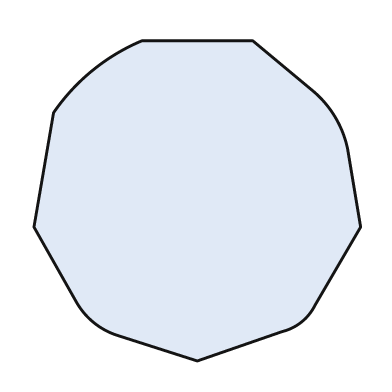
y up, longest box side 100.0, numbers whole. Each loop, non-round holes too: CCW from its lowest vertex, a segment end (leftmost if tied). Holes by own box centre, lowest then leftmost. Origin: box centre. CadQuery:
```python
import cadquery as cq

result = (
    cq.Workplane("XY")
    .moveTo(0.0, -49.0)
    .lineTo(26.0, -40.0)
    .threePointArc((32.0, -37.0), (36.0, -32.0))
    .lineTo(50.0, -8.0)
    .lineTo(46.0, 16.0)
    .threePointArc((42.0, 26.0), (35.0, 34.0))
    .lineTo(17.0, 49.0)
    .lineTo(-17.0, 49.0)
    .threePointArc((-32.0, 40.0), (-44.0, 27.0))
    .lineTo(-50.0, -8.0)
    .lineTo(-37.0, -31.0)
    .threePointArc((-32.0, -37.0), (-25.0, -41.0))
    .close()
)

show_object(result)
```